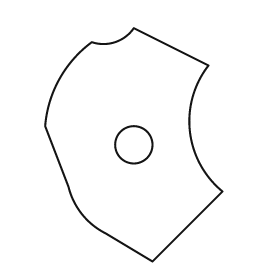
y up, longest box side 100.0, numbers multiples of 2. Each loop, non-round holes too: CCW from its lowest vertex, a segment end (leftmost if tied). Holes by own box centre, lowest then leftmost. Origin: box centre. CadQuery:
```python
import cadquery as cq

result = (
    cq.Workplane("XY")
    .moveTo(8.0, -50.0)
    .lineTo(38.0, -20.0)
    .threePointArc((24.0, 6.0), (32.0, 34.0))
    .lineTo(0.0, 50.0)
    .threePointArc((-8.0, 44.0), (-18.0, 44.0))
    .threePointArc((-32.0, 28.0), (-38.0, 8.0))
    .lineTo(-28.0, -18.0)
    .threePointArc((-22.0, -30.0), (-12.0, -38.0))
    .close()
    .moveTo(0.0, 0.0)
    .circle(8.0)
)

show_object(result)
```